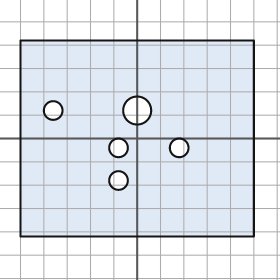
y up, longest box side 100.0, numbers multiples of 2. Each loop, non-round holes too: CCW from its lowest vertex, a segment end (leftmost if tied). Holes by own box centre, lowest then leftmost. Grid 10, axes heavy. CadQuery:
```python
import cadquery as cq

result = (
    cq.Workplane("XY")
    .moveTo(-50.0, -42.0)
    .lineTo(50.0, -42.0)
    .lineTo(50.0, 42.0)
    .lineTo(-50.0, 42.0)
    .close()
    .moveTo(-8.0, -18.0)
    .circle(4.0)
    .moveTo(-8.0, -4.0)
    .circle(4.0)
    .moveTo(18.0, -4.0)
    .circle(4.0)
    .moveTo(-36.0, 12.0)
    .circle(4.0)
    .moveTo(0.0, 12.0)
    .circle(6.0)
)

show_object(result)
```